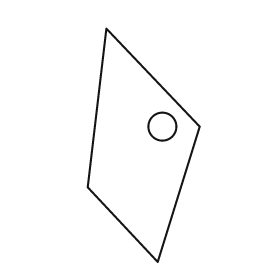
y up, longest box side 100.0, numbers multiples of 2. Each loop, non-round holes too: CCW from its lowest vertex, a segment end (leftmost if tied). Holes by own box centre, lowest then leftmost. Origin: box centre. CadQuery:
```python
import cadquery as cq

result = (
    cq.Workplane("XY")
    .moveTo(6.0, -50.0)
    .lineTo(24.0, 8.0)
    .lineTo(-16.0, 50.0)
    .lineTo(-24.0, -18.0)
    .close()
    .moveTo(8.0, 8.0)
    .circle(6.0)
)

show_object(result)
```